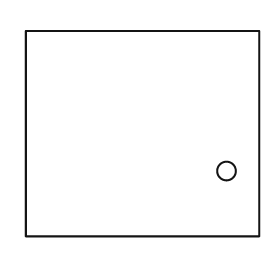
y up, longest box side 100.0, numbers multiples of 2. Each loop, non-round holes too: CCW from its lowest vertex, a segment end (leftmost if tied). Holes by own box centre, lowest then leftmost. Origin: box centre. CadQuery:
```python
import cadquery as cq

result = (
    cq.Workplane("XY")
    .moveTo(-50.0, -44.0)
    .lineTo(50.0, -44.0)
    .lineTo(50.0, 44.0)
    .lineTo(-50.0, 44.0)
    .close()
    .moveTo(36.0, -16.0)
    .circle(4.0)
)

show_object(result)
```